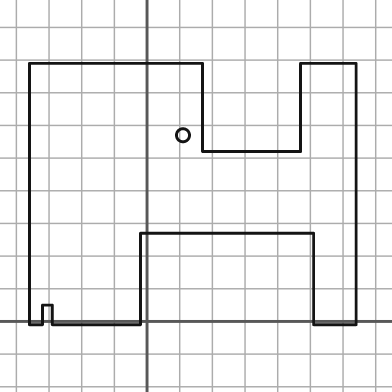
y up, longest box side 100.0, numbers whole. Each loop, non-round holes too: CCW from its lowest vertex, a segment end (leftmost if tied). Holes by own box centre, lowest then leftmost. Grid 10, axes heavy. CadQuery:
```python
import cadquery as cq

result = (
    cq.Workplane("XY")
    .moveTo(-36.0, -1.0)
    .lineTo(-32.0, -1.0)
    .lineTo(-32.0, 5.0)
    .lineTo(-29.0, 5.0)
    .lineTo(-29.0, -1.0)
    .lineTo(-2.0, -1.0)
    .lineTo(-2.0, 27.0)
    .lineTo(51.0, 27.0)
    .lineTo(51.0, -1.0)
    .lineTo(64.0, -1.0)
    .lineTo(64.0, 79.0)
    .lineTo(47.0, 79.0)
    .lineTo(47.0, 52.0)
    .lineTo(17.0, 52.0)
    .lineTo(17.0, 79.0)
    .lineTo(-36.0, 79.0)
    .close()
    .moveTo(11.0, 57.0)
    .circle(2.0)
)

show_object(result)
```